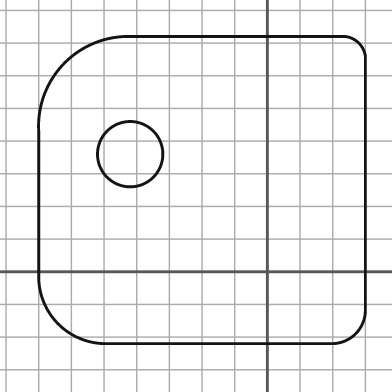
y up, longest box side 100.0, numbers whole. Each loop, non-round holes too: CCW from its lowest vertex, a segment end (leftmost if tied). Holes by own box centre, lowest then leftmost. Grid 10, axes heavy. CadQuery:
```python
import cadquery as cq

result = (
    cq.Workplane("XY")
    .moveTo(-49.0, -22.0)
    .lineTo(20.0, -22.0)
    .threePointArc((27.0, -19.0), (30.0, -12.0))
    .lineTo(30.0, 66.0)
    .threePointArc((28.0, 70.0), (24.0, 72.0))
    .lineTo(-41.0, 72.0)
    .threePointArc((-62.0, 64.0), (-70.0, 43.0))
    .lineTo(-70.0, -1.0)
    .threePointArc((-64.0, -16.0), (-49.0, -22.0))
    .close()
    .moveTo(-42.0, 36.0)
    .circle(10.0)
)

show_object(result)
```